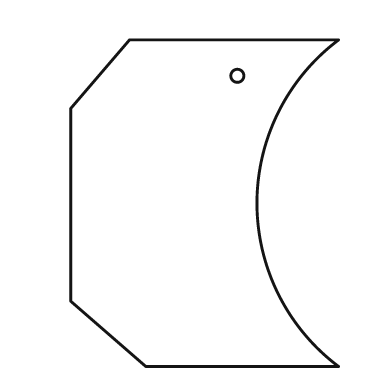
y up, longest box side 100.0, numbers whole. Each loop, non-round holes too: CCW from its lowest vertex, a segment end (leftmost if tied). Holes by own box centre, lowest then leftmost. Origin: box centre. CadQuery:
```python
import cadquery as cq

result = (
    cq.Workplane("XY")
    .moveTo(-18.0, -50.0)
    .lineTo(41.0, -50.0)
    .threePointArc((16.0, 0.0), (41.0, 50.0))
    .lineTo(-23.0, 50.0)
    .lineTo(-41.0, 29.0)
    .lineTo(-41.0, -30.0)
    .close()
    .moveTo(10.0, 39.0)
    .circle(2.0)
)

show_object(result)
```